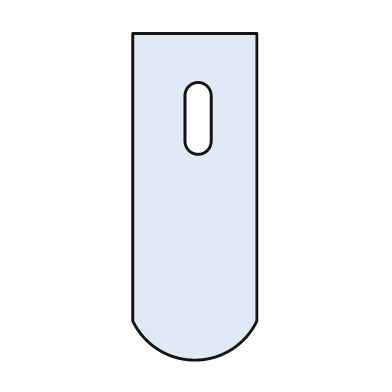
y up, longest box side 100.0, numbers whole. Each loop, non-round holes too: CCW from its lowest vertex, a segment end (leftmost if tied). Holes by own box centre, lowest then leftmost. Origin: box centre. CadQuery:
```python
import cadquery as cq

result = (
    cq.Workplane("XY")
    .moveTo(-19.0, -38.0)
    .threePointArc((0.0, -50.0), (19.0, -38.0))
    .lineTo(19.0, 50.0)
    .lineTo(-19.0, 50.0)
    .close()
    .moveTo(-3.0, 17.0)
    .threePointArc((1.0, 13.0), (5.0, 17.0))
    .lineTo(5.0, 31.0)
    .threePointArc((1.0, 35.0), (-3.0, 31.0))
    .close()
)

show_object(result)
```